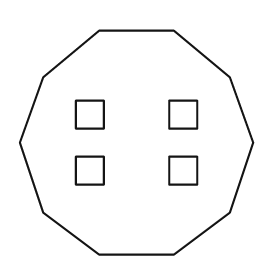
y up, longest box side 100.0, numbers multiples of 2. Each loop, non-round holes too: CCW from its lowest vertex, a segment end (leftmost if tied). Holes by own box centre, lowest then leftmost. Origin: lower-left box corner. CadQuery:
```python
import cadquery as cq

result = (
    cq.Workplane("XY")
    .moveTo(34.0, 0.0)
    .lineTo(66.0, 0.0)
    .lineTo(90.0, 18.0)
    .lineTo(100.0, 48.0)
    .lineTo(90.0, 76.0)
    .lineTo(66.0, 96.0)
    .lineTo(34.0, 96.0)
    .lineTo(10.0, 76.0)
    .lineTo(0.0, 48.0)
    .lineTo(10.0, 18.0)
    .close()
    .moveTo(24.0, 30.0)
    .lineTo(36.0, 30.0)
    .lineTo(36.0, 42.0)
    .lineTo(24.0, 42.0)
    .close()
    .moveTo(64.0, 30.0)
    .lineTo(76.0, 30.0)
    .lineTo(76.0, 42.0)
    .lineTo(64.0, 42.0)
    .close()
    .moveTo(24.0, 54.0)
    .lineTo(36.0, 54.0)
    .lineTo(36.0, 66.0)
    .lineTo(24.0, 66.0)
    .close()
    .moveTo(64.0, 54.0)
    .lineTo(76.0, 54.0)
    .lineTo(76.0, 66.0)
    .lineTo(64.0, 66.0)
    .close()
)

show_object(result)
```